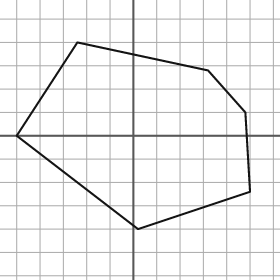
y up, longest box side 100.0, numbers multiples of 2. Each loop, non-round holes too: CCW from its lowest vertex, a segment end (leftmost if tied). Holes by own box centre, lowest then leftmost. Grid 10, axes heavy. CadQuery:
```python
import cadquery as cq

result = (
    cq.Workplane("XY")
    .moveTo(2.0, -40.0)
    .lineTo(50.0, -24.0)
    .lineTo(48.0, 10.0)
    .lineTo(32.0, 28.0)
    .lineTo(-24.0, 40.0)
    .lineTo(-50.0, 0.0)
    .close()
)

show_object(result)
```